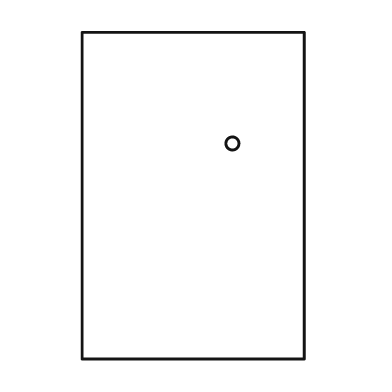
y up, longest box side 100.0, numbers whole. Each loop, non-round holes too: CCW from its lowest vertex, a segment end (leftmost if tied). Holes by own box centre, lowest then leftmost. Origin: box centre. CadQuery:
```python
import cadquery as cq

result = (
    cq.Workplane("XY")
    .moveTo(-34.0, -50.0)
    .lineTo(34.0, -50.0)
    .lineTo(34.0, 50.0)
    .lineTo(-34.0, 50.0)
    .close()
    .moveTo(12.0, 16.0)
    .circle(2.0)
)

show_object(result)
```